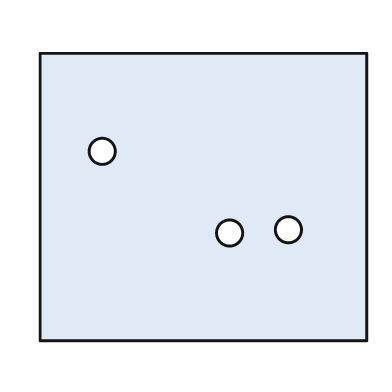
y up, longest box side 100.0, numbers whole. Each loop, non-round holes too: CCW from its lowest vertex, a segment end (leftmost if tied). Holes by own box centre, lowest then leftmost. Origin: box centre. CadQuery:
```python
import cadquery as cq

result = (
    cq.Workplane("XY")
    .moveTo(-50.0, -44.0)
    .lineTo(50.0, -44.0)
    .lineTo(50.0, 44.0)
    .lineTo(-50.0, 44.0)
    .close()
    .moveTo(8.0, -11.0)
    .circle(4.0)
    .moveTo(26.0, -10.0)
    .circle(4.0)
    .moveTo(-31.0, 14.0)
    .circle(4.0)
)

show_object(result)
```